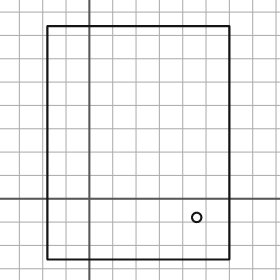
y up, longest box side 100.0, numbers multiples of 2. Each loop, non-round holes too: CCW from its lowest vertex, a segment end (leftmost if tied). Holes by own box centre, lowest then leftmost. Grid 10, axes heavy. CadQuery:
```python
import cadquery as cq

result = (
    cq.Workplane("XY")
    .moveTo(-18.0, -26.0)
    .lineTo(60.0, -26.0)
    .lineTo(60.0, 74.0)
    .lineTo(-18.0, 74.0)
    .close()
    .moveTo(46.0, -8.0)
    .circle(2.0)
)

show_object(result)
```